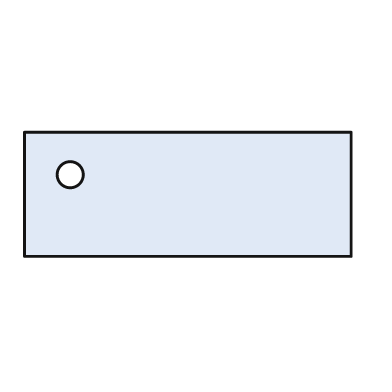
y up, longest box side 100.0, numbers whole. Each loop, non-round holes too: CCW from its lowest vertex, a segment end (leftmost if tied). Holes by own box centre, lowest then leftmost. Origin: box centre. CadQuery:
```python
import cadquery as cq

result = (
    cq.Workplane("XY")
    .moveTo(-50.0, -19.0)
    .lineTo(50.0, -19.0)
    .lineTo(50.0, 19.0)
    .lineTo(-50.0, 19.0)
    .close()
    .moveTo(-36.0, 6.0)
    .circle(4.0)
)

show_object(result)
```